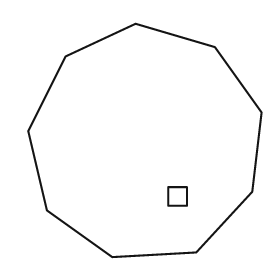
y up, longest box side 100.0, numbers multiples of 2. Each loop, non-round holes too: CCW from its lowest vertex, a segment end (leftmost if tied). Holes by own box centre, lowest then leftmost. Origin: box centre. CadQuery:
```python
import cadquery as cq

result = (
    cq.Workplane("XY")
    .moveTo(-14.0, -50.0)
    .lineTo(22.0, -48.0)
    .lineTo(46.0, -22.0)
    .lineTo(50.0, 12.0)
    .lineTo(30.0, 40.0)
    .lineTo(-4.0, 50.0)
    .lineTo(-34.0, 36.0)
    .lineTo(-50.0, 4.0)
    .lineTo(-42.0, -30.0)
    .close()
    .moveTo(10.0, -28.0)
    .lineTo(18.0, -28.0)
    .lineTo(18.0, -20.0)
    .lineTo(10.0, -20.0)
    .close()
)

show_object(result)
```